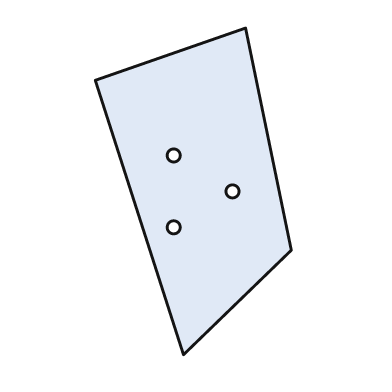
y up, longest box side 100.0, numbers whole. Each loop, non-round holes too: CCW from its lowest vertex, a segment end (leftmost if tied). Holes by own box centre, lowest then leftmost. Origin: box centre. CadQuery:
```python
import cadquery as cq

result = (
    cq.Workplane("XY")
    .moveTo(-3.0, -50.0)
    .lineTo(30.0, -18.0)
    .lineTo(16.0, 50.0)
    .lineTo(-30.0, 34.0)
    .close()
    .moveTo(-6.0, -11.0)
    .circle(2.0)
    .moveTo(12.0, 0.0)
    .circle(2.0)
    .moveTo(-6.0, 11.0)
    .circle(2.0)
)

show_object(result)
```